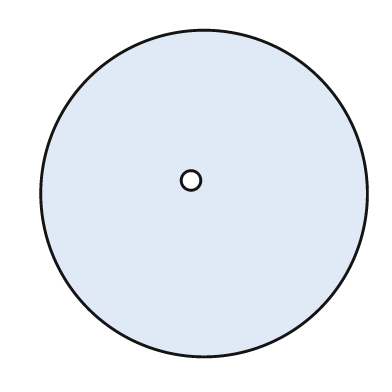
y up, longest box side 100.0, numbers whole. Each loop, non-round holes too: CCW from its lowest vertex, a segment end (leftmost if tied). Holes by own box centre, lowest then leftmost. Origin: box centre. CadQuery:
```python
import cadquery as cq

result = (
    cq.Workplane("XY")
    .moveTo(0.0, 0.0)
    .circle(50.0)
    .moveTo(-4.0, 4.0)
    .circle(3.0)
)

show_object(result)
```